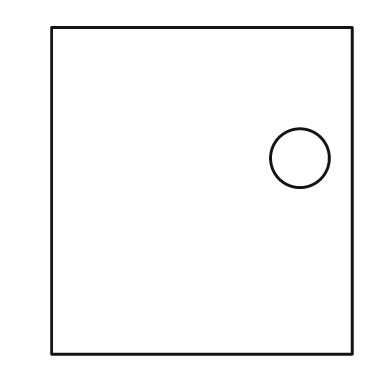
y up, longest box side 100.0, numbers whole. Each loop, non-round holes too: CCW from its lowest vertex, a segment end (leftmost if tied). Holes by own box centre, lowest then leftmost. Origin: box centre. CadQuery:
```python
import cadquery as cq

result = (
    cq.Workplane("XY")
    .moveTo(-46.0, -50.0)
    .lineTo(46.0, -50.0)
    .lineTo(46.0, 50.0)
    .lineTo(-46.0, 50.0)
    .close()
    .moveTo(30.0, 10.0)
    .circle(9.0)
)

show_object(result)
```